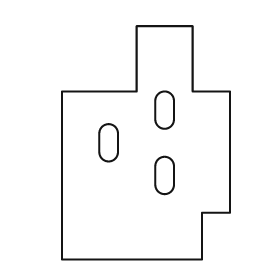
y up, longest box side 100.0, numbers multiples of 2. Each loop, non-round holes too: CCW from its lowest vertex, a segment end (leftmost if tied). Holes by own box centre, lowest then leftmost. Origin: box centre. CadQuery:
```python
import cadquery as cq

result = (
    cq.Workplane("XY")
    .moveTo(-36.0, -50.0)
    .lineTo(24.0, -50.0)
    .lineTo(24.0, -30.0)
    .lineTo(36.0, -30.0)
    .lineTo(36.0, 22.0)
    .lineTo(20.0, 22.0)
    .lineTo(20.0, 50.0)
    .lineTo(-4.0, 50.0)
    .lineTo(-4.0, 22.0)
    .lineTo(-36.0, 22.0)
    .close()
    .moveTo(4.0, -18.0)
    .threePointArc((8.0, -22.0), (12.0, -18.0))
    .lineTo(12.0, -10.0)
    .threePointArc((8.0, -6.0), (4.0, -10.0))
    .close()
    .moveTo(-20.0, -4.0)
    .threePointArc((-16.0, -8.0), (-12.0, -4.0))
    .lineTo(-12.0, 4.0)
    .threePointArc((-16.0, 8.0), (-20.0, 4.0))
    .close()
    .moveTo(4.0, 10.0)
    .threePointArc((8.0, 6.0), (12.0, 10.0))
    .lineTo(12.0, 18.0)
    .threePointArc((8.0, 22.0), (4.0, 18.0))
    .close()
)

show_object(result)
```